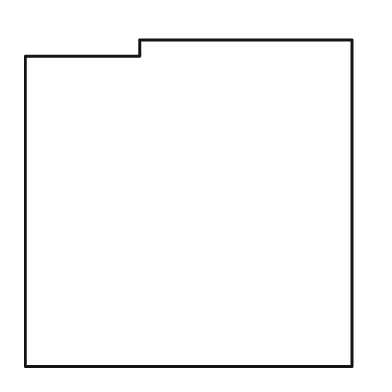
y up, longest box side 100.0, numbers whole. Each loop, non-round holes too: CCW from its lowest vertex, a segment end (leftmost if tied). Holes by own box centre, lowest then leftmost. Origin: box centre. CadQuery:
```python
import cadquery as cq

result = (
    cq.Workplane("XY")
    .moveTo(-50.0, -50.0)
    .lineTo(50.0, -50.0)
    .lineTo(50.0, 50.0)
    .lineTo(-15.0, 50.0)
    .lineTo(-15.0, 45.0)
    .lineTo(-50.0, 45.0)
    .close()
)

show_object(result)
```